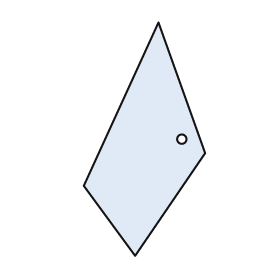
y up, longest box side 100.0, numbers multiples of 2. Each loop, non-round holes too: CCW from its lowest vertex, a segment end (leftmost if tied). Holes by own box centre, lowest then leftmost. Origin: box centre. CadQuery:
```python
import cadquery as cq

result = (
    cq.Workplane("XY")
    .moveTo(-4.0, -50.0)
    .lineTo(26.0, -6.0)
    .lineTo(6.0, 50.0)
    .lineTo(-26.0, -20.0)
    .close()
    .moveTo(16.0, 0.0)
    .circle(2.0)
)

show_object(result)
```